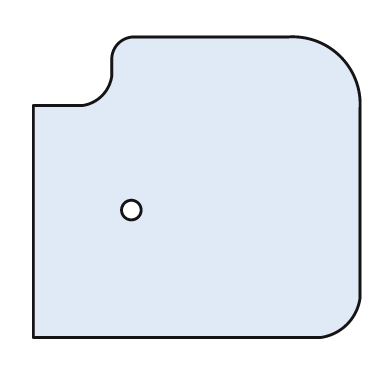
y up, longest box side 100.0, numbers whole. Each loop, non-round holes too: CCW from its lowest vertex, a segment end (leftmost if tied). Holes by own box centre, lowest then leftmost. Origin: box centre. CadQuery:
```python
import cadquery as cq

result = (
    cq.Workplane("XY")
    .moveTo(-50.0, -46.0)
    .lineTo(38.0, -46.0)
    .threePointArc((46.0, -42.0), (50.0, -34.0))
    .lineTo(50.0, 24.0)
    .threePointArc((44.0, 40.0), (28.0, 46.0))
    .lineTo(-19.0, 46.0)
    .threePointArc((-24.0, 44.0), (-26.0, 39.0))
    .lineTo(-26.0, 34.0)
    .threePointArc((-29.0, 28.0), (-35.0, 25.0))
    .lineTo(-50.0, 25.0)
    .close()
    .moveTo(-20.0, -7.0)
    .circle(3.0)
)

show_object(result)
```